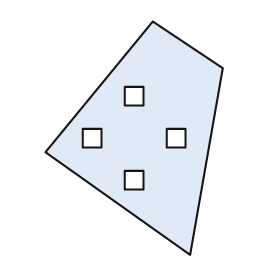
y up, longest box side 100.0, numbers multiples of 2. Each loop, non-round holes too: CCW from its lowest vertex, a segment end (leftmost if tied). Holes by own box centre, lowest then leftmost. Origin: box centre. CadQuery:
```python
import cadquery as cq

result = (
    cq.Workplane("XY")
    .moveTo(24.0, -50.0)
    .lineTo(38.0, 30.0)
    .lineTo(8.0, 50.0)
    .lineTo(-38.0, -6.0)
    .close()
    .moveTo(-4.0, -22.0)
    .lineTo(4.0, -22.0)
    .lineTo(4.0, -14.0)
    .lineTo(-4.0, -14.0)
    .close()
    .moveTo(-22.0, -4.0)
    .lineTo(-14.0, -4.0)
    .lineTo(-14.0, 4.0)
    .lineTo(-22.0, 4.0)
    .close()
    .moveTo(14.0, -4.0)
    .lineTo(22.0, -4.0)
    .lineTo(22.0, 4.0)
    .lineTo(14.0, 4.0)
    .close()
    .moveTo(-4.0, 14.0)
    .lineTo(4.0, 14.0)
    .lineTo(4.0, 22.0)
    .lineTo(-4.0, 22.0)
    .close()
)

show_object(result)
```